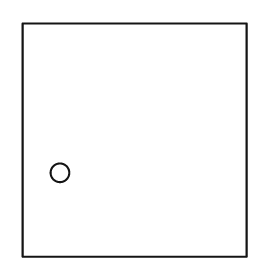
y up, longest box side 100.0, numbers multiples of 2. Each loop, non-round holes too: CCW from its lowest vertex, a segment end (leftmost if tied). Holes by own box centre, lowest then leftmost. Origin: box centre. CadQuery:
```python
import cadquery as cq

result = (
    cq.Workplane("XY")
    .moveTo(-48.0, -50.0)
    .lineTo(48.0, -50.0)
    .lineTo(48.0, 50.0)
    .lineTo(-48.0, 50.0)
    .close()
    .moveTo(-32.0, -14.0)
    .circle(4.0)
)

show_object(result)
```